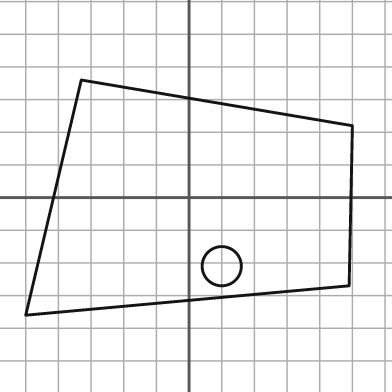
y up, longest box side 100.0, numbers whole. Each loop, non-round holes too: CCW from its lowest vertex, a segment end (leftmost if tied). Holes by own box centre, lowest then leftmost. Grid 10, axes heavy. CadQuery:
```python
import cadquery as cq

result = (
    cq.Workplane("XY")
    .moveTo(-50.0, -36.0)
    .lineTo(49.0, -27.0)
    .lineTo(50.0, 22.0)
    .lineTo(-33.0, 36.0)
    .close()
    .moveTo(10.0, -21.0)
    .circle(6.0)
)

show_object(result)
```